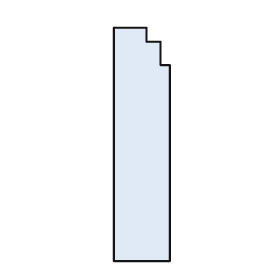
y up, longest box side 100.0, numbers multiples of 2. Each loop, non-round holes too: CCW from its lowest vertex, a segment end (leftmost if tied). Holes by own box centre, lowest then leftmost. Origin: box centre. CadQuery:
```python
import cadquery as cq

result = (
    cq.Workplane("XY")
    .moveTo(-12.0, -50.0)
    .lineTo(12.0, -50.0)
    .lineTo(12.0, 34.0)
    .lineTo(8.0, 34.0)
    .lineTo(8.0, 44.0)
    .lineTo(2.0, 44.0)
    .lineTo(2.0, 50.0)
    .lineTo(-12.0, 50.0)
    .close()
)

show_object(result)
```